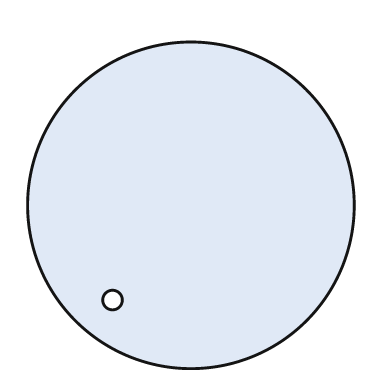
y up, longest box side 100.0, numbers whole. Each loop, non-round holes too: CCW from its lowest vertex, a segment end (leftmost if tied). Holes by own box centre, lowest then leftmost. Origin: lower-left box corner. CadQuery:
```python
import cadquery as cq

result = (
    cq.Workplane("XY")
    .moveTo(50.0, 50.0)
    .circle(50.0)
    .moveTo(26.0, 21.0)
    .circle(3.0)
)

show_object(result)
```